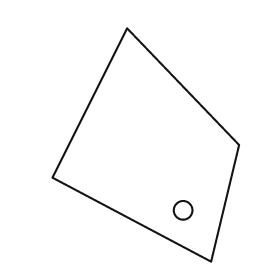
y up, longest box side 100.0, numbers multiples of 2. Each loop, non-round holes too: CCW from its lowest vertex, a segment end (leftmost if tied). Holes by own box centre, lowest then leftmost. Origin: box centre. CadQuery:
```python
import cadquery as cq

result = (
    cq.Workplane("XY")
    .moveTo(28.0, -50.0)
    .lineTo(40.0, 0.0)
    .lineTo(-8.0, 50.0)
    .lineTo(-40.0, -14.0)
    .close()
    .moveTo(16.0, -28.0)
    .circle(4.0)
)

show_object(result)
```